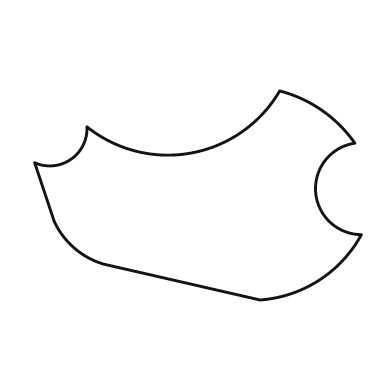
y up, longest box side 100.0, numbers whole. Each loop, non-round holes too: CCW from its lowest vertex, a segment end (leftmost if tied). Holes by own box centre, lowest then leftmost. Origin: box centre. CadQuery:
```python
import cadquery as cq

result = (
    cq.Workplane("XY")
    .moveTo(19.0, -32.0)
    .threePointArc((37.0, -26.0), (50.0, -12.0))
    .threePointArc((36.0, 1.0), (48.0, 16.0))
    .threePointArc((38.0, 26.0), (25.0, 32.0))
    .threePointArc((-2.0, 13.0), (-34.0, 21.0))
    .threePointArc((-39.0, 11.0), (-50.0, 10.0))
    .lineTo(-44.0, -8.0)
    .threePointArc((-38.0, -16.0), (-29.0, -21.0))
    .close()
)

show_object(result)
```